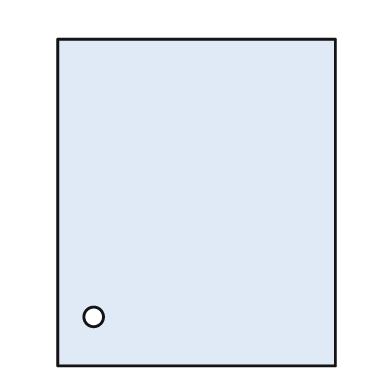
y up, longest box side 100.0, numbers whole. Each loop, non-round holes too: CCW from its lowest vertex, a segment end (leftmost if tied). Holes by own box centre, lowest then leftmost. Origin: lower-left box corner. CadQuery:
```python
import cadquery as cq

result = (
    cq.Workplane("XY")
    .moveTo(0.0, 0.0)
    .lineTo(85.0, 0.0)
    .lineTo(85.0, 100.0)
    .lineTo(0.0, 100.0)
    .close()
    .moveTo(11.0, 15.0)
    .circle(3.0)
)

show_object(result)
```